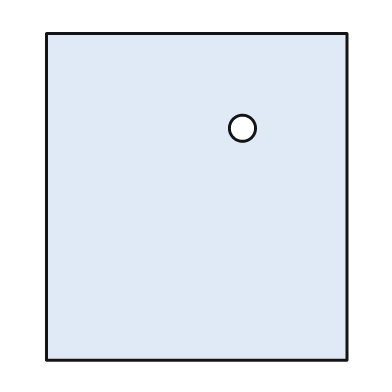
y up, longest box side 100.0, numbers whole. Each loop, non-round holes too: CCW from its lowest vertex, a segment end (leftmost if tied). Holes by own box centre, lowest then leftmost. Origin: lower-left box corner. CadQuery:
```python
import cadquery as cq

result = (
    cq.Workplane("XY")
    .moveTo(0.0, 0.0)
    .lineTo(92.0, 0.0)
    .lineTo(92.0, 100.0)
    .lineTo(0.0, 100.0)
    .close()
    .moveTo(60.0, 71.0)
    .circle(4.0)
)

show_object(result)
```